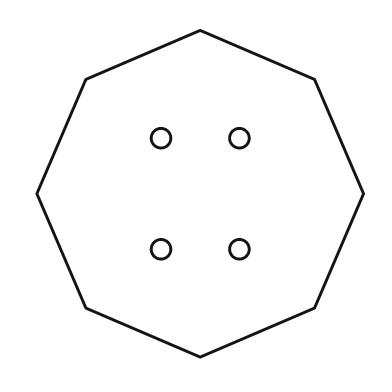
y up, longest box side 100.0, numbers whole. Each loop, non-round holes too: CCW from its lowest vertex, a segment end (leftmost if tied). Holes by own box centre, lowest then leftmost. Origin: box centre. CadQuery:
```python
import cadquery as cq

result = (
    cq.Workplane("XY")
    .moveTo(0.0, -50.0)
    .lineTo(35.0, -35.0)
    .lineTo(50.0, 0.0)
    .lineTo(35.0, 35.0)
    .lineTo(0.0, 50.0)
    .lineTo(-35.0, 35.0)
    .lineTo(-50.0, 0.0)
    .lineTo(-35.0, -35.0)
    .close()
    .moveTo(-12.0, -17.0)
    .circle(3.0)
    .moveTo(12.0, -17.0)
    .circle(3.0)
    .moveTo(-12.0, 17.0)
    .circle(3.0)
    .moveTo(12.0, 17.0)
    .circle(3.0)
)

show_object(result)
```